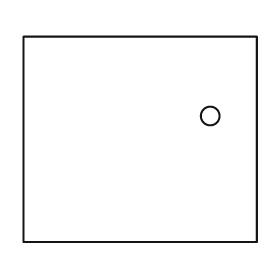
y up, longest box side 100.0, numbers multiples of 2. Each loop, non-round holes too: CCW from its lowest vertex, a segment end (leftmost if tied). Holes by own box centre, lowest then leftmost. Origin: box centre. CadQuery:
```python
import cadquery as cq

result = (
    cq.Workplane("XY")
    .moveTo(-50.0, -44.0)
    .lineTo(50.0, -44.0)
    .lineTo(50.0, 44.0)
    .lineTo(-50.0, 44.0)
    .close()
    .moveTo(30.0, 10.0)
    .circle(4.0)
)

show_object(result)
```